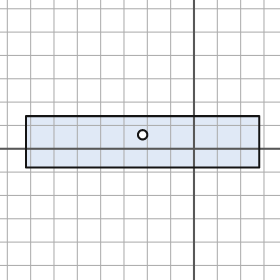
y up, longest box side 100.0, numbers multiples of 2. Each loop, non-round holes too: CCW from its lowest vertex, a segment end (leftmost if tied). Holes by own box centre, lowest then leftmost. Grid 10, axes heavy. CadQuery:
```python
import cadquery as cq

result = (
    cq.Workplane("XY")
    .moveTo(-72.0, -8.0)
    .lineTo(28.0, -8.0)
    .lineTo(28.0, 14.0)
    .lineTo(-72.0, 14.0)
    .close()
    .moveTo(-22.0, 6.0)
    .circle(2.0)
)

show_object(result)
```